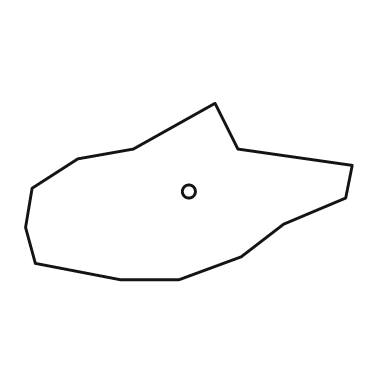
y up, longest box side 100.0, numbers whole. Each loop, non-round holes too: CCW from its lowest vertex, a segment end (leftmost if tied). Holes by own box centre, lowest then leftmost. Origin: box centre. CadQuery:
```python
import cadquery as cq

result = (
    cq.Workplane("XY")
    .moveTo(-21.0, -27.0)
    .lineTo(-3.0, -27.0)
    .lineTo(16.0, -20.0)
    .lineTo(29.0, -10.0)
    .lineTo(48.0, -2.0)
    .lineTo(50.0, 8.0)
    .lineTo(15.0, 13.0)
    .lineTo(8.0, 27.0)
    .lineTo(-17.0, 13.0)
    .lineTo(-34.0, 10.0)
    .lineTo(-48.0, 1.0)
    .lineTo(-50.0, -11.0)
    .lineTo(-47.0, -22.0)
    .close()
    .moveTo(0.0, 0.0)
    .circle(2.0)
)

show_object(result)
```